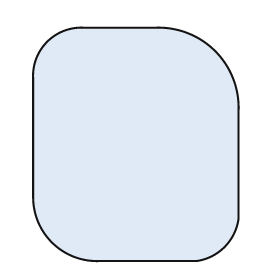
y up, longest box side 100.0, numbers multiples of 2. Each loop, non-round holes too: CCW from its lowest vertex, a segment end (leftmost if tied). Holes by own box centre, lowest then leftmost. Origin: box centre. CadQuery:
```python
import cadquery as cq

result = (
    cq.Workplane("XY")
    .moveTo(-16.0, -50.0)
    .lineTo(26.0, -50.0)
    .threePointArc((38.0, -44.0), (44.0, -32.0))
    .lineTo(44.0, 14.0)
    .threePointArc((34.0, 40.0), (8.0, 50.0))
    .lineTo(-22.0, 50.0)
    .threePointArc((-38.0, 44.0), (-44.0, 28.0))
    .lineTo(-44.0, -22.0)
    .threePointArc((-36.0, -42.0), (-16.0, -50.0))
    .close()
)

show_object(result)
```